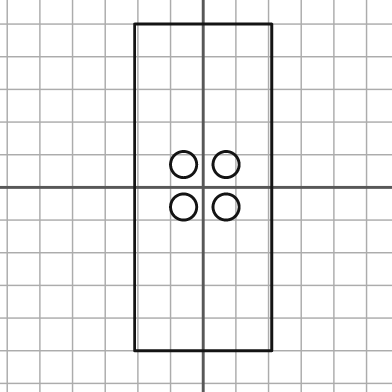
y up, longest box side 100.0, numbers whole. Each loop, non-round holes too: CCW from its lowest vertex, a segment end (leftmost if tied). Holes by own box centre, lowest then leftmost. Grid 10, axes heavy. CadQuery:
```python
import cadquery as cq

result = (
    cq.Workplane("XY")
    .moveTo(-21.0, -50.0)
    .lineTo(21.0, -50.0)
    .lineTo(21.0, 50.0)
    .lineTo(-21.0, 50.0)
    .close()
    .moveTo(-6.0, -6.0)
    .circle(4.0)
    .moveTo(7.0, -6.0)
    .circle(4.0)
    .moveTo(-6.0, 7.0)
    .circle(4.0)
    .moveTo(7.0, 7.0)
    .circle(4.0)
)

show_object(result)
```